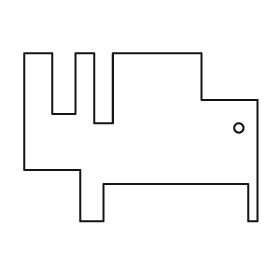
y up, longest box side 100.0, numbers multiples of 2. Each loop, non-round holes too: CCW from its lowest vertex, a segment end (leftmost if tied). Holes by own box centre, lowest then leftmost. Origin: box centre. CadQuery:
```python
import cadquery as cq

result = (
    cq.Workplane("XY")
    .moveTo(-26.0, -36.0)
    .lineTo(-16.0, -36.0)
    .lineTo(-16.0, -20.0)
    .lineTo(46.0, -20.0)
    .lineTo(46.0, -36.0)
    .lineTo(50.0, -36.0)
    .lineTo(50.0, 16.0)
    .lineTo(26.0, 16.0)
    .lineTo(26.0, 36.0)
    .lineTo(-12.0, 36.0)
    .lineTo(-12.0, 6.0)
    .lineTo(-20.0, 6.0)
    .lineTo(-20.0, 36.0)
    .lineTo(-28.0, 36.0)
    .lineTo(-28.0, 10.0)
    .lineTo(-38.0, 10.0)
    .lineTo(-38.0, 36.0)
    .lineTo(-50.0, 36.0)
    .lineTo(-50.0, -14.0)
    .lineTo(-26.0, -14.0)
    .close()
    .moveTo(42.0, 4.0)
    .circle(2.0)
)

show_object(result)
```